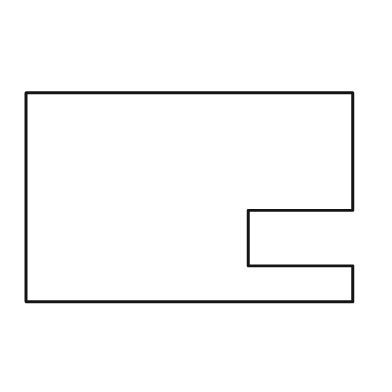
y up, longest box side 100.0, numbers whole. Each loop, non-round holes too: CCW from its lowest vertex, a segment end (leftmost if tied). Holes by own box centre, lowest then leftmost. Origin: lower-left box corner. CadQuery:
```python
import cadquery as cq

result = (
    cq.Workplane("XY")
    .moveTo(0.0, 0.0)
    .lineTo(100.0, 0.0)
    .lineTo(100.0, 11.0)
    .lineTo(68.0, 11.0)
    .lineTo(68.0, 28.0)
    .lineTo(100.0, 28.0)
    .lineTo(100.0, 64.0)
    .lineTo(0.0, 64.0)
    .close()
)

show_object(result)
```